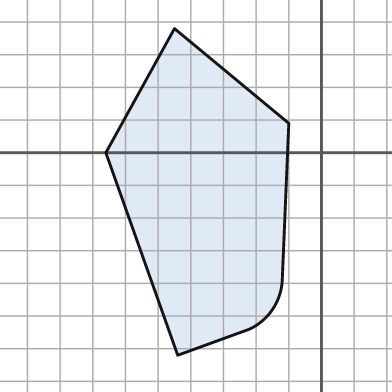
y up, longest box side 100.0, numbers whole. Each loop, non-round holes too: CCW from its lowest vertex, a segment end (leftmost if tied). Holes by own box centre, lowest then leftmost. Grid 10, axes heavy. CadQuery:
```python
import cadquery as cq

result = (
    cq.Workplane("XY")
    .moveTo(-44.0, -62.0)
    .lineTo(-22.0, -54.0)
    .threePointArc((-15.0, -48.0), (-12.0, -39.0))
    .lineTo(-10.0, 9.0)
    .lineTo(-45.0, 38.0)
    .lineTo(-66.0, 0.0)
    .close()
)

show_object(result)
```